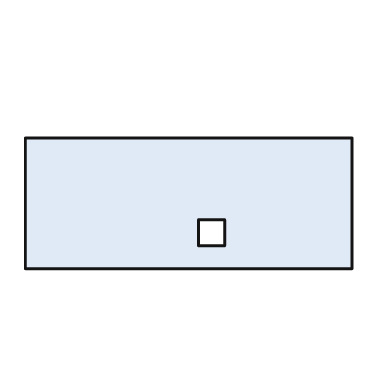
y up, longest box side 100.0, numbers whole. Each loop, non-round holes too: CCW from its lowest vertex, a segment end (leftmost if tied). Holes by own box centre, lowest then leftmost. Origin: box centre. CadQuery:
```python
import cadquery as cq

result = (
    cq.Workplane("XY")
    .moveTo(-50.0, -20.0)
    .lineTo(50.0, -20.0)
    .lineTo(50.0, 20.0)
    .lineTo(-50.0, 20.0)
    .close()
    .moveTo(3.0, -13.0)
    .lineTo(11.0, -13.0)
    .lineTo(11.0, -5.0)
    .lineTo(3.0, -5.0)
    .close()
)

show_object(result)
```